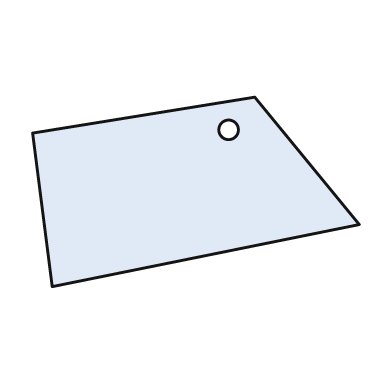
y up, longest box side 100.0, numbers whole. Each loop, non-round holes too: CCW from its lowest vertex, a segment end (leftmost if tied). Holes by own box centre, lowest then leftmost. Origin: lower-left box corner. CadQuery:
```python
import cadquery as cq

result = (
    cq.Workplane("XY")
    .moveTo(6.0, 0.0)
    .lineTo(100.0, 19.0)
    .lineTo(68.0, 58.0)
    .lineTo(0.0, 47.0)
    .close()
    .moveTo(60.0, 48.0)
    .circle(3.0)
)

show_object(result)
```